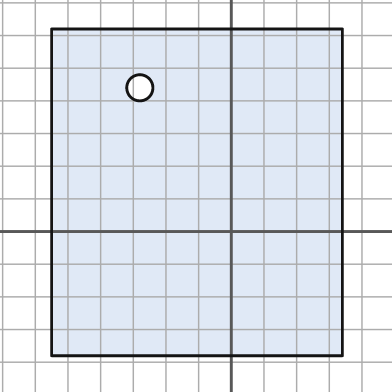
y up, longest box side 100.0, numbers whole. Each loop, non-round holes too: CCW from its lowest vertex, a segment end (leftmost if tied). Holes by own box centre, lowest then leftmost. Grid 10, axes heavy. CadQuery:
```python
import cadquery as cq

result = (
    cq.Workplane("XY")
    .moveTo(-55.0, -38.0)
    .lineTo(34.0, -38.0)
    .lineTo(34.0, 62.0)
    .lineTo(-55.0, 62.0)
    .close()
    .moveTo(-28.0, 44.0)
    .circle(4.0)
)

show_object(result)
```